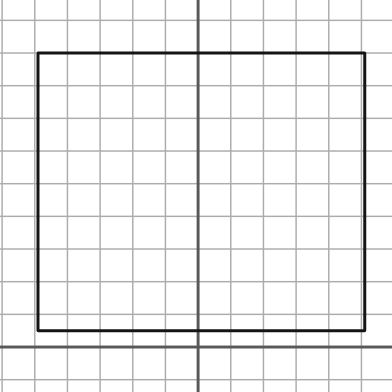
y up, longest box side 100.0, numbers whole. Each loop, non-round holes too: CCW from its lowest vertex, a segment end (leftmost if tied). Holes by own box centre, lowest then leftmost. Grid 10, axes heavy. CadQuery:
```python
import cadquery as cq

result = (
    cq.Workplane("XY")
    .moveTo(-49.0, 5.0)
    .lineTo(51.0, 5.0)
    .lineTo(51.0, 90.0)
    .lineTo(-49.0, 90.0)
    .close()
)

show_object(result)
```